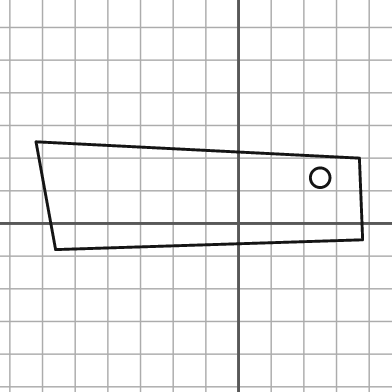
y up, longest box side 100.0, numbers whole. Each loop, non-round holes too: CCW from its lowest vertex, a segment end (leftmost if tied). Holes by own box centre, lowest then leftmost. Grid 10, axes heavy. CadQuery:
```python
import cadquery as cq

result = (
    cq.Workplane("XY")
    .moveTo(-56.0, -8.0)
    .lineTo(38.0, -5.0)
    .lineTo(37.0, 20.0)
    .lineTo(-62.0, 25.0)
    .close()
    .moveTo(25.0, 14.0)
    .circle(3.0)
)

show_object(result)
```